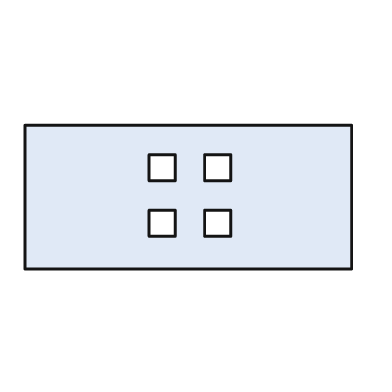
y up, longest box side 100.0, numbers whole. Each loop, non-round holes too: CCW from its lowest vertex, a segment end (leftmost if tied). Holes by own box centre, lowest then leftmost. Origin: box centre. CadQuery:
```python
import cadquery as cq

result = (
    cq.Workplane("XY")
    .moveTo(-50.0, -22.0)
    .lineTo(50.0, -22.0)
    .lineTo(50.0, 22.0)
    .lineTo(-50.0, 22.0)
    .close()
    .moveTo(-12.0, -12.0)
    .lineTo(-4.0, -12.0)
    .lineTo(-4.0, -4.0)
    .lineTo(-12.0, -4.0)
    .close()
    .moveTo(5.0, -12.0)
    .lineTo(13.0, -12.0)
    .lineTo(13.0, -4.0)
    .lineTo(5.0, -4.0)
    .close()
    .moveTo(-12.0, 5.0)
    .lineTo(-4.0, 5.0)
    .lineTo(-4.0, 13.0)
    .lineTo(-12.0, 13.0)
    .close()
    .moveTo(5.0, 5.0)
    .lineTo(13.0, 5.0)
    .lineTo(13.0, 13.0)
    .lineTo(5.0, 13.0)
    .close()
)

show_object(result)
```